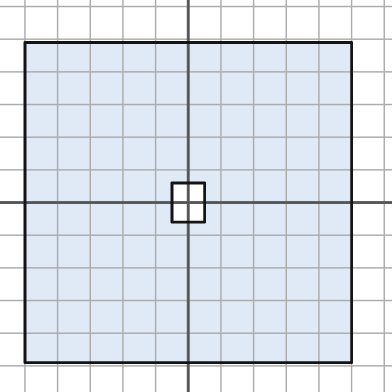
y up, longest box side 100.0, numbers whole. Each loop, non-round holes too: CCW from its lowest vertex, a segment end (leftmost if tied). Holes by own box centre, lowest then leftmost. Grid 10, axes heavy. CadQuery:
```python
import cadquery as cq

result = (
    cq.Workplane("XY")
    .moveTo(-50.0, -49.0)
    .lineTo(50.0, -49.0)
    .lineTo(50.0, 49.0)
    .lineTo(-50.0, 49.0)
    .close()
    .moveTo(-5.0, -6.0)
    .lineTo(5.0, -6.0)
    .lineTo(5.0, 6.0)
    .lineTo(-5.0, 6.0)
    .close()
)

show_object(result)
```